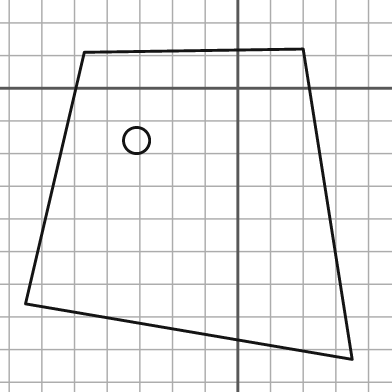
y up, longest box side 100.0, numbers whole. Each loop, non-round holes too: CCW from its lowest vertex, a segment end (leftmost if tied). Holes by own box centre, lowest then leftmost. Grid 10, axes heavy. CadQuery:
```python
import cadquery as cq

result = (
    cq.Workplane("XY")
    .moveTo(35.0, -83.0)
    .lineTo(20.0, 12.0)
    .lineTo(-47.0, 11.0)
    .lineTo(-65.0, -66.0)
    .close()
    .moveTo(-31.0, -16.0)
    .circle(4.0)
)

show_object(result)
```